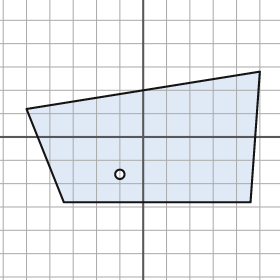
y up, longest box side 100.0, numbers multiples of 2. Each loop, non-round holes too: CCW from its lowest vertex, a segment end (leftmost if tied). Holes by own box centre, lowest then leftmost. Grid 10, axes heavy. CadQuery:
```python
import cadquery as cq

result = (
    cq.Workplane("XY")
    .moveTo(-34.0, -28.0)
    .lineTo(46.0, -28.0)
    .lineTo(50.0, 28.0)
    .lineTo(-50.0, 12.0)
    .close()
    .moveTo(-10.0, -16.0)
    .circle(2.0)
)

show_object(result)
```